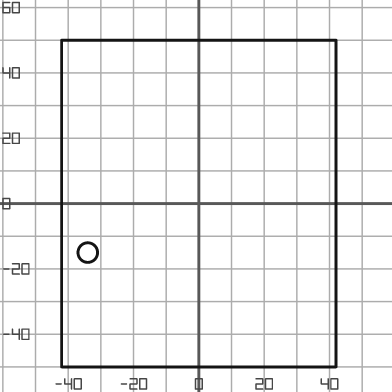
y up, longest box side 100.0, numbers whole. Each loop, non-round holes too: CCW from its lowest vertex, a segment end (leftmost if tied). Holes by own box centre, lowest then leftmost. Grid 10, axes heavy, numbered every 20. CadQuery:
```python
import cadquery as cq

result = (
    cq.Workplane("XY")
    .moveTo(-42.0, -50.0)
    .lineTo(42.0, -50.0)
    .lineTo(42.0, 50.0)
    .lineTo(-42.0, 50.0)
    .close()
    .moveTo(-34.0, -15.0)
    .circle(3.0)
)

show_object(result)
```